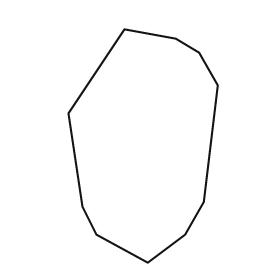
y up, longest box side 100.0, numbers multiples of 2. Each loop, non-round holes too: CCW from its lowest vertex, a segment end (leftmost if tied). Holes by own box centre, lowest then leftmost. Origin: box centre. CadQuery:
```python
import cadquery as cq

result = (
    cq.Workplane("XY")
    .moveTo(2.0, -50.0)
    .lineTo(18.0, -38.0)
    .lineTo(26.0, -24.0)
    .lineTo(32.0, 26.0)
    .lineTo(24.0, 40.0)
    .lineTo(14.0, 46.0)
    .lineTo(-8.0, 50.0)
    .lineTo(-32.0, 14.0)
    .lineTo(-26.0, -26.0)
    .lineTo(-20.0, -38.0)
    .close()
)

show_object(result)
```